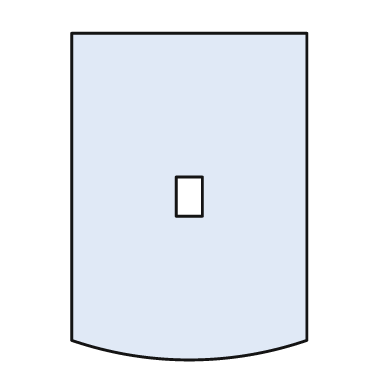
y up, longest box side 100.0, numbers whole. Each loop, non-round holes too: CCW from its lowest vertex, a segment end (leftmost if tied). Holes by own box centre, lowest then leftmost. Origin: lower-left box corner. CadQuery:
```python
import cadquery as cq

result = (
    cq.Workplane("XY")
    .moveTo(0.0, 6.0)
    .threePointArc((36.0, 0.0), (72.0, 6.0))
    .lineTo(72.0, 100.0)
    .lineTo(0.0, 100.0)
    .close()
    .moveTo(32.0, 44.0)
    .lineTo(40.0, 44.0)
    .lineTo(40.0, 56.0)
    .lineTo(32.0, 56.0)
    .close()
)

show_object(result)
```